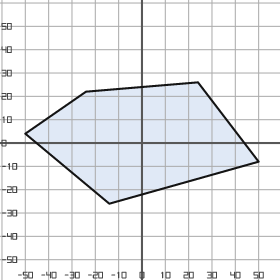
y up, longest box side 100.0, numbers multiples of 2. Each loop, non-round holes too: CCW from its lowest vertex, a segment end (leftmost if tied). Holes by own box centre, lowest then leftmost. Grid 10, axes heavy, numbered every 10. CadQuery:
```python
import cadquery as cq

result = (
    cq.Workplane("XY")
    .moveTo(-14.0, -26.0)
    .lineTo(50.0, -8.0)
    .lineTo(24.0, 26.0)
    .lineTo(-24.0, 22.0)
    .lineTo(-50.0, 4.0)
    .close()
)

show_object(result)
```